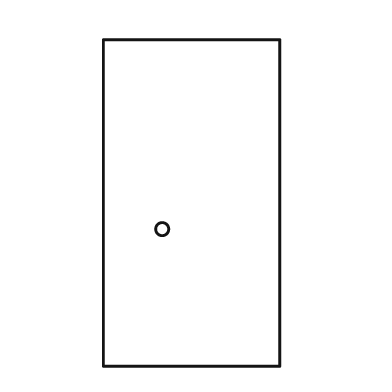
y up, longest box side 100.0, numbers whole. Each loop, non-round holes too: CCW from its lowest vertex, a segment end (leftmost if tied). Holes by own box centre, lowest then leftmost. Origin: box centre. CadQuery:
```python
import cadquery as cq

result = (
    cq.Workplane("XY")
    .moveTo(-27.0, -50.0)
    .lineTo(27.0, -50.0)
    .lineTo(27.0, 50.0)
    .lineTo(-27.0, 50.0)
    .close()
    .moveTo(-9.0, -8.0)
    .circle(2.0)
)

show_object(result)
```